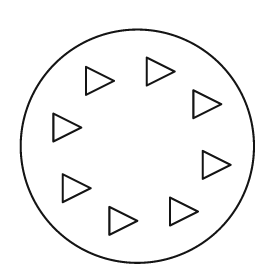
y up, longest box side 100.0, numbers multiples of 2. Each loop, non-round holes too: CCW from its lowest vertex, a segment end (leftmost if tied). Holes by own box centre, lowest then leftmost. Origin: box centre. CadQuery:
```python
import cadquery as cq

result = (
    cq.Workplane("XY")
    .moveTo(0.0, 0.0)
    .circle(50.0)
    .moveTo(-12.0, -38.0)
    .lineTo(0.0, -32.0)
    .lineTo(-12.0, -26.0)
    .close()
    .moveTo(14.0, -34.0)
    .lineTo(26.0, -28.0)
    .lineTo(14.0, -22.0)
    .close()
    .moveTo(-32.0, -24.0)
    .lineTo(-20.0, -18.0)
    .lineTo(-32.0, -12.0)
    .close()
    .moveTo(28.0, -14.0)
    .lineTo(40.0, -8.0)
    .lineTo(28.0, -2.0)
    .close()
    .moveTo(-36.0, 2.0)
    .lineTo(-24.0, 8.0)
    .lineTo(-36.0, 14.0)
    .close()
    .moveTo(24.0, 12.0)
    .lineTo(36.0, 18.0)
    .lineTo(24.0, 24.0)
    .close()
    .moveTo(-22.0, 22.0)
    .lineTo(-10.0, 28.0)
    .lineTo(-22.0, 34.0)
    .close()
    .moveTo(4.0, 26.0)
    .lineTo(16.0, 32.0)
    .lineTo(4.0, 38.0)
    .close()
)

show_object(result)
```